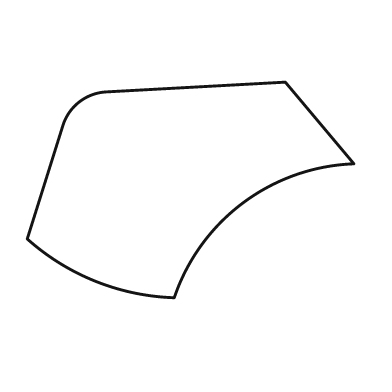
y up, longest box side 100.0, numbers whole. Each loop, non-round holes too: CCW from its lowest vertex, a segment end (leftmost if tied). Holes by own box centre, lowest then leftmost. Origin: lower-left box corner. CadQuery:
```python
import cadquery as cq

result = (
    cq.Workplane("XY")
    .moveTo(45.0, 0.0)
    .threePointArc((66.0, 29.0), (100.0, 41.0))
    .lineTo(79.0, 66.0)
    .lineTo(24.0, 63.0)
    .threePointArc((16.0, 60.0), (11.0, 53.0))
    .lineTo(0.0, 18.0)
    .threePointArc((21.0, 5.0), (45.0, 0.0))
    .close()
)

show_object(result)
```